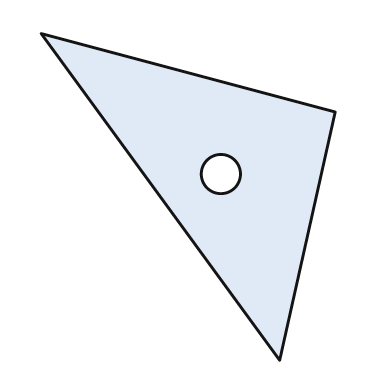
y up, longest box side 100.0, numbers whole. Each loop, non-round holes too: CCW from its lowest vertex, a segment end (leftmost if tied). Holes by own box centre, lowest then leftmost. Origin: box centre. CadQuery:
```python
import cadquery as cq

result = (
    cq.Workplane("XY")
    .moveTo(28.0, -50.0)
    .lineTo(45.0, 26.0)
    .lineTo(-45.0, 50.0)
    .close()
    .moveTo(10.0, 7.0)
    .circle(6.0)
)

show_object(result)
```